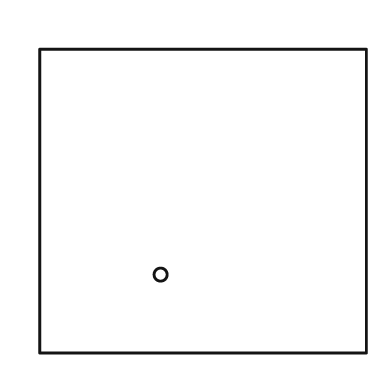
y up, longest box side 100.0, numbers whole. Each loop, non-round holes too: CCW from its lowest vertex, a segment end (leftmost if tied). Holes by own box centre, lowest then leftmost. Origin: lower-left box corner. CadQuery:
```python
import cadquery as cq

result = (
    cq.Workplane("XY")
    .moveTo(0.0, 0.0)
    .lineTo(100.0, 0.0)
    .lineTo(100.0, 93.0)
    .lineTo(0.0, 93.0)
    .close()
    .moveTo(37.0, 24.0)
    .circle(2.0)
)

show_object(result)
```